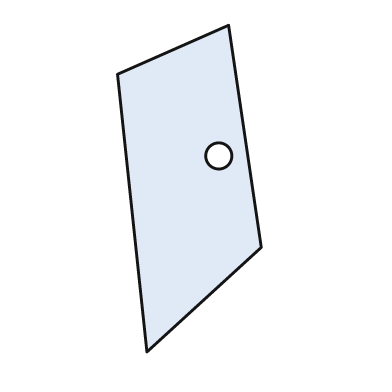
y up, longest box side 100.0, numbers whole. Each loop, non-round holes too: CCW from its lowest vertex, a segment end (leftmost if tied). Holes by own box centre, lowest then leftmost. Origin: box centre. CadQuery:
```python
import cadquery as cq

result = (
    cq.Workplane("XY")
    .moveTo(-13.0, -50.0)
    .lineTo(22.0, -18.0)
    .lineTo(12.0, 50.0)
    .lineTo(-22.0, 35.0)
    .close()
    .moveTo(9.0, 10.0)
    .circle(4.0)
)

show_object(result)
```